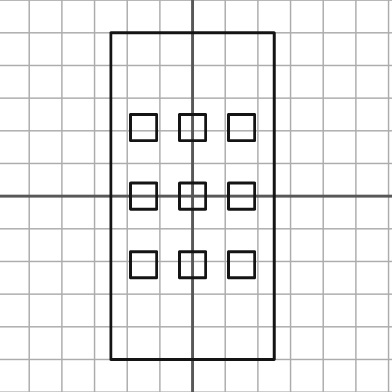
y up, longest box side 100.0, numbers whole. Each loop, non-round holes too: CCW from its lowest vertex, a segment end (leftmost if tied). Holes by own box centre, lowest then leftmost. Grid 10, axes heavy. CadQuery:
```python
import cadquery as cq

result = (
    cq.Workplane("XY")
    .moveTo(-25.0, -50.0)
    .lineTo(25.0, -50.0)
    .lineTo(25.0, 50.0)
    .lineTo(-25.0, 50.0)
    .close()
    .moveTo(-19.0, -25.0)
    .lineTo(-11.0, -25.0)
    .lineTo(-11.0, -17.0)
    .lineTo(-19.0, -17.0)
    .close()
    .moveTo(-4.0, -25.0)
    .lineTo(4.0, -25.0)
    .lineTo(4.0, -17.0)
    .lineTo(-4.0, -17.0)
    .close()
    .moveTo(11.0, -25.0)
    .lineTo(19.0, -25.0)
    .lineTo(19.0, -17.0)
    .lineTo(11.0, -17.0)
    .close()
    .moveTo(-19.0, -4.0)
    .lineTo(-11.0, -4.0)
    .lineTo(-11.0, 4.0)
    .lineTo(-19.0, 4.0)
    .close()
    .moveTo(-4.0, -4.0)
    .lineTo(4.0, -4.0)
    .lineTo(4.0, 4.0)
    .lineTo(-4.0, 4.0)
    .close()
    .moveTo(11.0, -4.0)
    .lineTo(19.0, -4.0)
    .lineTo(19.0, 4.0)
    .lineTo(11.0, 4.0)
    .close()
    .moveTo(-19.0, 17.0)
    .lineTo(-11.0, 17.0)
    .lineTo(-11.0, 25.0)
    .lineTo(-19.0, 25.0)
    .close()
    .moveTo(-4.0, 17.0)
    .lineTo(4.0, 17.0)
    .lineTo(4.0, 25.0)
    .lineTo(-4.0, 25.0)
    .close()
    .moveTo(11.0, 17.0)
    .lineTo(19.0, 17.0)
    .lineTo(19.0, 25.0)
    .lineTo(11.0, 25.0)
    .close()
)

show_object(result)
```